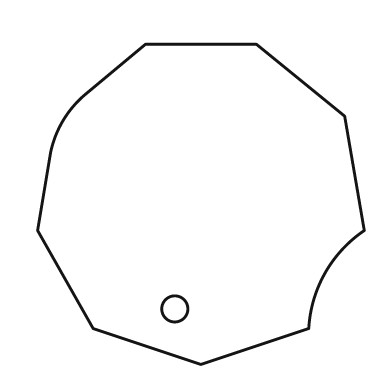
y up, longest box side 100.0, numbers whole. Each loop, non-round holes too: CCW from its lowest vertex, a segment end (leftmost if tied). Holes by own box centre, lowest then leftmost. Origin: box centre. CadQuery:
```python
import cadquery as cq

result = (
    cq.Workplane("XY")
    .moveTo(0.0, -49.0)
    .lineTo(33.0, -38.0)
    .threePointArc((38.0, -21.0), (50.0, -8.0))
    .lineTo(44.0, 27.0)
    .lineTo(17.0, 49.0)
    .lineTo(-17.0, 49.0)
    .lineTo(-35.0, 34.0)
    .threePointArc((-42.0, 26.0), (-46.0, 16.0))
    .lineTo(-50.0, -8.0)
    .lineTo(-33.0, -38.0)
    .close()
    .moveTo(-8.0, -32.0)
    .circle(4.0)
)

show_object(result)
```